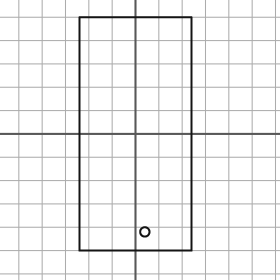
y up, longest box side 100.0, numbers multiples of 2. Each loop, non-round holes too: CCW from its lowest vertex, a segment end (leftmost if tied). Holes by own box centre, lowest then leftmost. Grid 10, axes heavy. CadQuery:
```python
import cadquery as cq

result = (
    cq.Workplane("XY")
    .moveTo(-24.0, -50.0)
    .lineTo(24.0, -50.0)
    .lineTo(24.0, 50.0)
    .lineTo(-24.0, 50.0)
    .close()
    .moveTo(4.0, -42.0)
    .circle(2.0)
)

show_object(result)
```